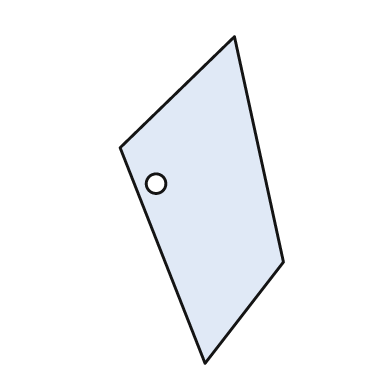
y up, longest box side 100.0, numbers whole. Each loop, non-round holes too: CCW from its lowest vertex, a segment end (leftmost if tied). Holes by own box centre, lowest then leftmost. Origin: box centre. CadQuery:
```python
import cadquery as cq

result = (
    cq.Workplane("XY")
    .moveTo(1.0, -50.0)
    .lineTo(25.0, -19.0)
    .lineTo(10.0, 50.0)
    .lineTo(-25.0, 16.0)
    .close()
    .moveTo(-14.0, 5.0)
    .circle(3.0)
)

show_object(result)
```